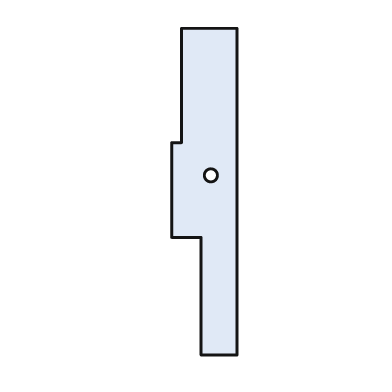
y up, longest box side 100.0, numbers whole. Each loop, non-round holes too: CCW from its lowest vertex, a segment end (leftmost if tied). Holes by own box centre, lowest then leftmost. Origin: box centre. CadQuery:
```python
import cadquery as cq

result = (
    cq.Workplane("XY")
    .moveTo(-1.0, -50.0)
    .lineTo(10.0, -50.0)
    .lineTo(10.0, 50.0)
    .lineTo(-7.0, 50.0)
    .lineTo(-7.0, 15.0)
    .lineTo(-10.0, 15.0)
    .lineTo(-10.0, -14.0)
    .lineTo(-1.0, -14.0)
    .close()
    .moveTo(2.0, 5.0)
    .circle(2.0)
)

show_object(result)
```